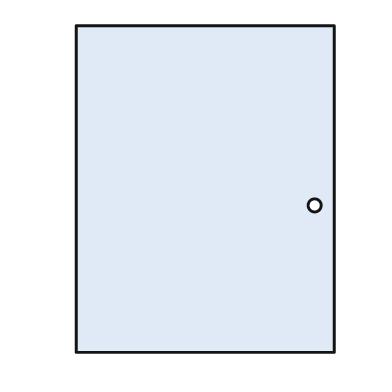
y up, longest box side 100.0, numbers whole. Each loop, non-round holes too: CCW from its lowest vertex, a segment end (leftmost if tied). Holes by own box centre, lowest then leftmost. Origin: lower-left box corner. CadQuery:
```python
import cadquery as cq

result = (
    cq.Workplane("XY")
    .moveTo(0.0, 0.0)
    .lineTo(79.0, 0.0)
    .lineTo(79.0, 100.0)
    .lineTo(0.0, 100.0)
    .close()
    .moveTo(73.0, 45.0)
    .circle(2.0)
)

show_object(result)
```